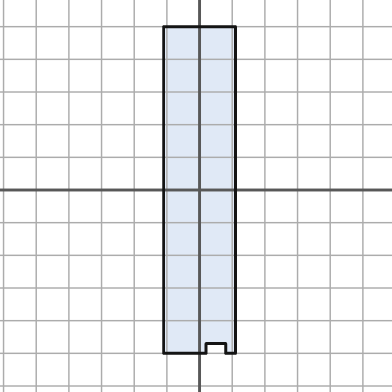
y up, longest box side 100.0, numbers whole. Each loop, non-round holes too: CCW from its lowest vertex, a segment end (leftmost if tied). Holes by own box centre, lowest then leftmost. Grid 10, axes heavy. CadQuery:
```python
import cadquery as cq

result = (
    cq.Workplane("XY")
    .moveTo(-11.0, -50.0)
    .lineTo(2.0, -50.0)
    .lineTo(2.0, -47.0)
    .lineTo(8.0, -47.0)
    .lineTo(8.0, -50.0)
    .lineTo(11.0, -50.0)
    .lineTo(11.0, 50.0)
    .lineTo(-11.0, 50.0)
    .close()
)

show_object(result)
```